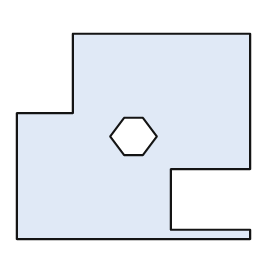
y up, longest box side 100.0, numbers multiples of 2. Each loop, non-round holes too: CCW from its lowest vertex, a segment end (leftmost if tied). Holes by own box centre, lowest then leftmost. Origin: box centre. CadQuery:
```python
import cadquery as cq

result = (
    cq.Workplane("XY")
    .moveTo(-50.0, -44.0)
    .lineTo(50.0, -44.0)
    .lineTo(50.0, -40.0)
    .lineTo(16.0, -40.0)
    .lineTo(16.0, -14.0)
    .lineTo(50.0, -14.0)
    .lineTo(50.0, 44.0)
    .lineTo(-26.0, 44.0)
    .lineTo(-26.0, 10.0)
    .lineTo(-50.0, 10.0)
    .close()
    .moveTo(-4.0, -8.0)
    .lineTo(4.0, -8.0)
    .lineTo(10.0, 0.0)
    .lineTo(4.0, 8.0)
    .lineTo(-4.0, 8.0)
    .lineTo(-10.0, 0.0)
    .close()
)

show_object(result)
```